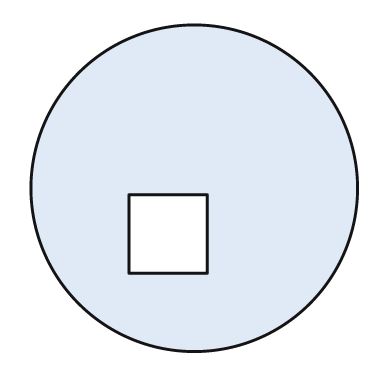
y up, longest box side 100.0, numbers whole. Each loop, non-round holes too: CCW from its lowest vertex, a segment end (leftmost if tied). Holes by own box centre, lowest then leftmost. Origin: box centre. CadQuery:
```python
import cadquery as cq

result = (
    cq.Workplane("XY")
    .moveTo(0.0, 0.0)
    .circle(50.0)
    .moveTo(-20.0, -26.0)
    .lineTo(4.0, -26.0)
    .lineTo(4.0, -2.0)
    .lineTo(-20.0, -2.0)
    .close()
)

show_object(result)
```